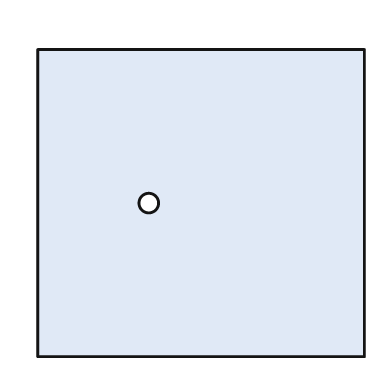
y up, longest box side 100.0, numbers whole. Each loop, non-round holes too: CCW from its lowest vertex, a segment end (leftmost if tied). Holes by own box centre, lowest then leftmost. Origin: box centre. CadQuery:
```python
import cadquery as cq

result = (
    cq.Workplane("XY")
    .moveTo(-50.0, -47.0)
    .lineTo(50.0, -47.0)
    .lineTo(50.0, 47.0)
    .lineTo(-50.0, 47.0)
    .close()
    .moveTo(-16.0, 0.0)
    .circle(3.0)
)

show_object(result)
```